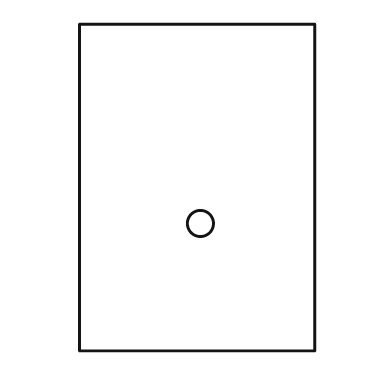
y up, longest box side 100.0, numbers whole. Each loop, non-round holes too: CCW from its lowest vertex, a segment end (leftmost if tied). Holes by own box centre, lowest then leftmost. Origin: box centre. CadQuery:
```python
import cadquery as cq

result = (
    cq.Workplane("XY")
    .moveTo(-36.0, -50.0)
    .lineTo(36.0, -50.0)
    .lineTo(36.0, 50.0)
    .lineTo(-36.0, 50.0)
    .close()
    .moveTo(1.0, -11.0)
    .circle(4.0)
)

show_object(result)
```